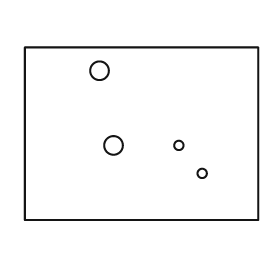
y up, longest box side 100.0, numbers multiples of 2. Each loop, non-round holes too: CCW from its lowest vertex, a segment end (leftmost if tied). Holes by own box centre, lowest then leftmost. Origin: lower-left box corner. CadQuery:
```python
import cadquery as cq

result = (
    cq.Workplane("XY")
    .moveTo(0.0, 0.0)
    .lineTo(100.0, 0.0)
    .lineTo(100.0, 74.0)
    .lineTo(0.0, 74.0)
    .close()
    .moveTo(76.0, 20.0)
    .circle(2.0)
    .moveTo(38.0, 32.0)
    .circle(4.0)
    .moveTo(66.0, 32.0)
    .circle(2.0)
    .moveTo(32.0, 64.0)
    .circle(4.0)
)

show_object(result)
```